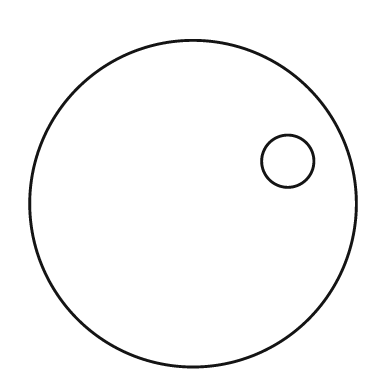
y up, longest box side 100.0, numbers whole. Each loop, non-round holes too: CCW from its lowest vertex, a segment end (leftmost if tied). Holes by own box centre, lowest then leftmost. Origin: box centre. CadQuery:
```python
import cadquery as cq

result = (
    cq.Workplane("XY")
    .moveTo(0.0, 0.0)
    .circle(50.0)
    .moveTo(29.0, 13.0)
    .circle(8.0)
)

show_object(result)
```